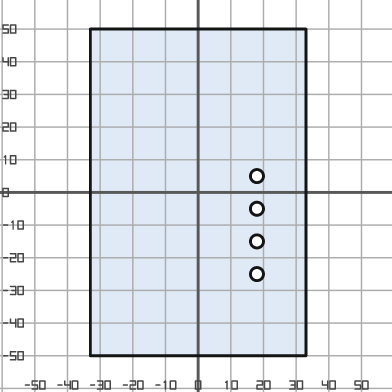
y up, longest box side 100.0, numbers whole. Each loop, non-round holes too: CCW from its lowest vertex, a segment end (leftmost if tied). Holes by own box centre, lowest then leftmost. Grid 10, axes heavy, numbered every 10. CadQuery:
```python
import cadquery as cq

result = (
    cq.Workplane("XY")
    .moveTo(-33.0, -50.0)
    .lineTo(33.0, -50.0)
    .lineTo(33.0, 50.0)
    .lineTo(-33.0, 50.0)
    .close()
    .moveTo(18.0, -25.0)
    .circle(2.0)
    .moveTo(18.0, -15.0)
    .circle(2.0)
    .moveTo(18.0, -5.0)
    .circle(2.0)
    .moveTo(18.0, 5.0)
    .circle(2.0)
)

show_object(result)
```